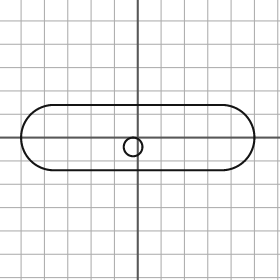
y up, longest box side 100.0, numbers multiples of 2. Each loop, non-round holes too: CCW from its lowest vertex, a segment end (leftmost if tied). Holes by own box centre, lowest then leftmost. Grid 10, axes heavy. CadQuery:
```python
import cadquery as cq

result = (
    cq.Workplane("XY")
    .moveTo(-36.0, -14.0)
    .lineTo(36.0, -14.0)
    .threePointArc((50.0, 0.0), (36.0, 14.0))
    .lineTo(-36.0, 14.0)
    .threePointArc((-50.0, 0.0), (-36.0, -14.0))
    .close()
    .moveTo(-2.0, -4.0)
    .circle(4.0)
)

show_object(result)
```